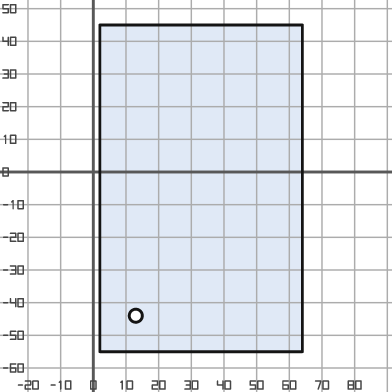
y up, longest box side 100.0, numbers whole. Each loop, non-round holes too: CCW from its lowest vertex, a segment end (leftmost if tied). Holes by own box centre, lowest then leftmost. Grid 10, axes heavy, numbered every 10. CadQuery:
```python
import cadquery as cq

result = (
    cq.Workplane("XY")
    .moveTo(2.0, -55.0)
    .lineTo(64.0, -55.0)
    .lineTo(64.0, 45.0)
    .lineTo(2.0, 45.0)
    .close()
    .moveTo(13.0, -44.0)
    .circle(2.0)
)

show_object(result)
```